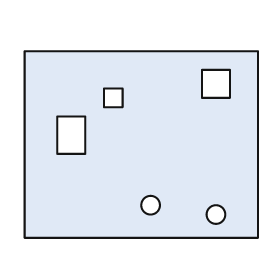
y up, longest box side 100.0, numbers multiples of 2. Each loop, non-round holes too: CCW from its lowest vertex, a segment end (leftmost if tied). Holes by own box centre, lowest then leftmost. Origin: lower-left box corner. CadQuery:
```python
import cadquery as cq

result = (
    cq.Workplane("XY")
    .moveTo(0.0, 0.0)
    .lineTo(100.0, 0.0)
    .lineTo(100.0, 80.0)
    .lineTo(0.0, 80.0)
    .close()
    .moveTo(82.0, 10.0)
    .circle(4.0)
    .moveTo(54.0, 14.0)
    .circle(4.0)
    .moveTo(14.0, 36.0)
    .lineTo(26.0, 36.0)
    .lineTo(26.0, 52.0)
    .lineTo(14.0, 52.0)
    .close()
    .moveTo(34.0, 56.0)
    .lineTo(42.0, 56.0)
    .lineTo(42.0, 64.0)
    .lineTo(34.0, 64.0)
    .close()
    .moveTo(76.0, 60.0)
    .lineTo(88.0, 60.0)
    .lineTo(88.0, 72.0)
    .lineTo(76.0, 72.0)
    .close()
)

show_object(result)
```